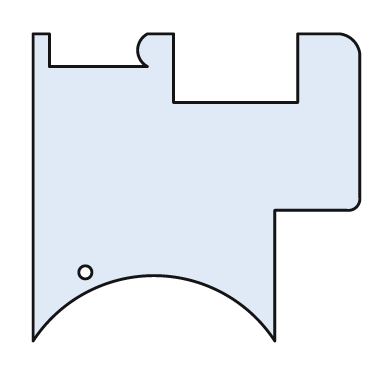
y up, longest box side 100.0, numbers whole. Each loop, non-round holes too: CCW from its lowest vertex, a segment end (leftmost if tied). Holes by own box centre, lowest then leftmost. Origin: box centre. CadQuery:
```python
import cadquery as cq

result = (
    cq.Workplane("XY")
    .moveTo(-50.0, -47.0)
    .threePointArc((-13.0, -27.0), (24.0, -47.0))
    .lineTo(24.0, -7.0)
    .lineTo(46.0, -7.0)
    .threePointArc((49.0, -6.0), (50.0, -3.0))
    .lineTo(50.0, 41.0)
    .threePointArc((48.0, 45.0), (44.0, 47.0))
    .lineTo(31.0, 47.0)
    .lineTo(31.0, 26.0)
    .lineTo(-7.0, 26.0)
    .lineTo(-7.0, 47.0)
    .lineTo(-15.0, 47.0)
    .threePointArc((-18.0, 42.0), (-15.0, 37.0))
    .lineTo(-45.0, 37.0)
    .lineTo(-45.0, 47.0)
    .lineTo(-50.0, 47.0)
    .close()
    .moveTo(-34.0, -26.0)
    .circle(2.0)
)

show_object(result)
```